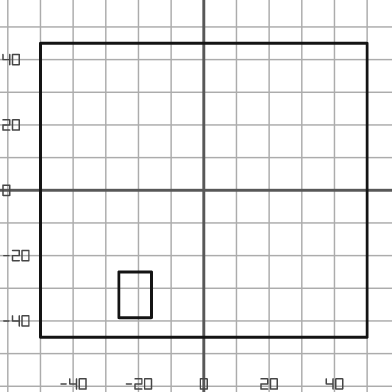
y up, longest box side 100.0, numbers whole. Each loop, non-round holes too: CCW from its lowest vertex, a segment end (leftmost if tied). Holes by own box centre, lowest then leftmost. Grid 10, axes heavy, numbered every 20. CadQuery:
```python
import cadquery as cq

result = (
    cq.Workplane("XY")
    .moveTo(-50.0, -45.0)
    .lineTo(50.0, -45.0)
    .lineTo(50.0, 45.0)
    .lineTo(-50.0, 45.0)
    .close()
    .moveTo(-26.0, -39.0)
    .lineTo(-16.0, -39.0)
    .lineTo(-16.0, -25.0)
    .lineTo(-26.0, -25.0)
    .close()
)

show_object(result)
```